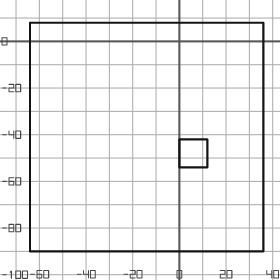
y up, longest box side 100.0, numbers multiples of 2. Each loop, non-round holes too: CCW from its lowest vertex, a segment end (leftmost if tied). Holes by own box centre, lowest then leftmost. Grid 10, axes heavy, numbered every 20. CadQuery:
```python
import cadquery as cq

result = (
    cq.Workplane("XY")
    .moveTo(-64.0, -90.0)
    .lineTo(36.0, -90.0)
    .lineTo(36.0, 8.0)
    .lineTo(-64.0, 8.0)
    .close()
    .moveTo(0.0, -54.0)
    .lineTo(12.0, -54.0)
    .lineTo(12.0, -42.0)
    .lineTo(0.0, -42.0)
    .close()
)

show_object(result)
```